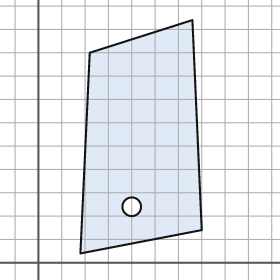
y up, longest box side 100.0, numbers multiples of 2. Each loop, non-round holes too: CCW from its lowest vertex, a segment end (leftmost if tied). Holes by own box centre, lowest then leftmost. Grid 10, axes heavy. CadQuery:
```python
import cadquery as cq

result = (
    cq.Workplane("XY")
    .moveTo(18.0, 4.0)
    .lineTo(70.0, 14.0)
    .lineTo(66.0, 104.0)
    .lineTo(22.0, 90.0)
    .close()
    .moveTo(40.0, 24.0)
    .circle(4.0)
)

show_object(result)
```